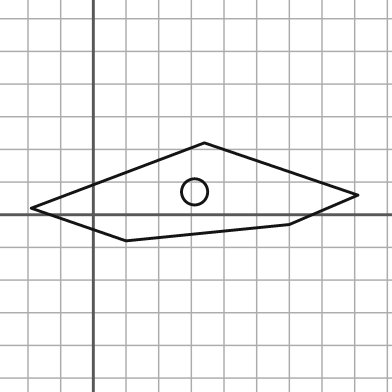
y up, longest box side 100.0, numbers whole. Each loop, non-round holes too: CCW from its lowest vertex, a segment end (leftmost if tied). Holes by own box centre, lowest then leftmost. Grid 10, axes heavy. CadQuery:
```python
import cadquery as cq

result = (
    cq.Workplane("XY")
    .moveTo(10.0, -8.0)
    .lineTo(60.0, -3.0)
    .lineTo(81.0, 6.0)
    .lineTo(34.0, 22.0)
    .lineTo(-19.0, 2.0)
    .close()
    .moveTo(31.0, 7.0)
    .circle(4.0)
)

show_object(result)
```